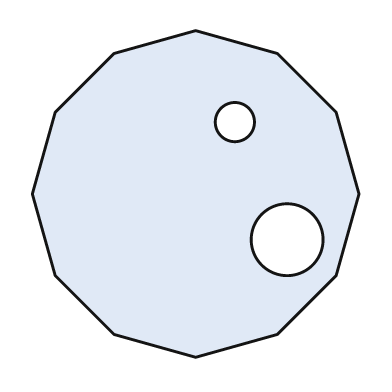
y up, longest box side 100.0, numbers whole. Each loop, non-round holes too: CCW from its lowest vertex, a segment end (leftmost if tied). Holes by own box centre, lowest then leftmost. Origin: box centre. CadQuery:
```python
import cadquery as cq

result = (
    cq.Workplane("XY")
    .moveTo(0.0, -50.0)
    .lineTo(25.0, -43.0)
    .lineTo(43.0, -25.0)
    .lineTo(50.0, 0.0)
    .lineTo(43.0, 25.0)
    .lineTo(25.0, 43.0)
    .lineTo(0.0, 50.0)
    .lineTo(-25.0, 43.0)
    .lineTo(-43.0, 25.0)
    .lineTo(-50.0, 0.0)
    .lineTo(-43.0, -25.0)
    .lineTo(-25.0, -43.0)
    .close()
    .moveTo(28.0, -14.0)
    .circle(11.0)
    .moveTo(12.0, 22.0)
    .circle(6.0)
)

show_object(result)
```